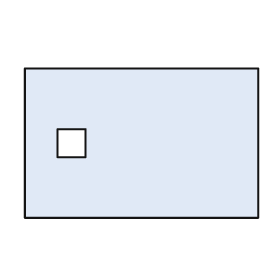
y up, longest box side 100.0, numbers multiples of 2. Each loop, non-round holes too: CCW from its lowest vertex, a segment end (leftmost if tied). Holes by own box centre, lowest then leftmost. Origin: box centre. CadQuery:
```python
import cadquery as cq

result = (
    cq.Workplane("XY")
    .moveTo(-50.0, -32.0)
    .lineTo(50.0, -32.0)
    .lineTo(50.0, 32.0)
    .lineTo(-50.0, 32.0)
    .close()
    .moveTo(-36.0, -6.0)
    .lineTo(-24.0, -6.0)
    .lineTo(-24.0, 6.0)
    .lineTo(-36.0, 6.0)
    .close()
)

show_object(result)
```